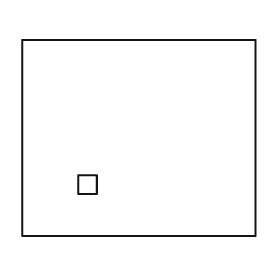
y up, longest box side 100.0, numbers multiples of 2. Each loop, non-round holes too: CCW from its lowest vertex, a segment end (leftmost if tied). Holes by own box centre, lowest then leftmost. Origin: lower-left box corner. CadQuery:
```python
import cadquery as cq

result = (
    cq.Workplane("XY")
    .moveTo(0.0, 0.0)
    .lineTo(100.0, 0.0)
    .lineTo(100.0, 84.0)
    .lineTo(0.0, 84.0)
    .close()
    .moveTo(24.0, 18.0)
    .lineTo(32.0, 18.0)
    .lineTo(32.0, 26.0)
    .lineTo(24.0, 26.0)
    .close()
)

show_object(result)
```